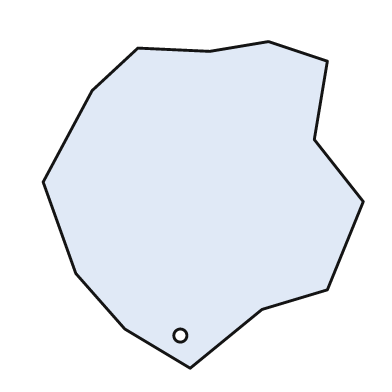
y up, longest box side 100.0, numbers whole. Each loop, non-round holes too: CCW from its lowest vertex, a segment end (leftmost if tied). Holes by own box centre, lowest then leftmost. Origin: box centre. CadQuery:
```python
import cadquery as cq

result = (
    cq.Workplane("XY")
    .moveTo(-4.0, -50.0)
    .lineTo(18.0, -32.0)
    .lineTo(38.0, -26.0)
    .lineTo(49.0, 1.0)
    .lineTo(34.0, 20.0)
    .lineTo(38.0, 44.0)
    .lineTo(20.0, 50.0)
    .lineTo(2.0, 47.0)
    .lineTo(-20.0, 48.0)
    .lineTo(-34.0, 35.0)
    .lineTo(-49.0, 7.0)
    .lineTo(-39.0, -21.0)
    .lineTo(-24.0, -38.0)
    .close()
    .moveTo(-7.0, -40.0)
    .circle(2.0)
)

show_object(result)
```